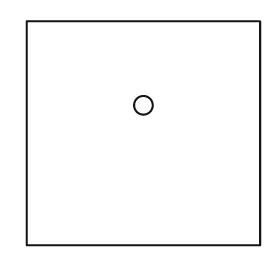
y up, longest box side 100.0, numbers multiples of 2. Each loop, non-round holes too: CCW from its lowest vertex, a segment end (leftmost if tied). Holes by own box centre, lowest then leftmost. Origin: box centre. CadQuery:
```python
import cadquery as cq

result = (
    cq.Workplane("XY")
    .moveTo(-50.0, -48.0)
    .lineTo(50.0, -48.0)
    .lineTo(50.0, 48.0)
    .lineTo(-50.0, 48.0)
    .close()
    .moveTo(0.0, 12.0)
    .circle(4.0)
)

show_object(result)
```